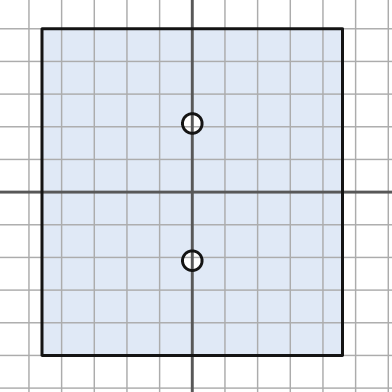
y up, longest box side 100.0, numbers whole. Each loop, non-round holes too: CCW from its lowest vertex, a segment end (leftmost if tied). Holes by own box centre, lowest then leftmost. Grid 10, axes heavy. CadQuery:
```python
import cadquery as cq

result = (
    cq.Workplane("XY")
    .moveTo(-46.0, -50.0)
    .lineTo(46.0, -50.0)
    .lineTo(46.0, 50.0)
    .lineTo(-46.0, 50.0)
    .close()
    .moveTo(0.0, -21.0)
    .circle(3.0)
    .moveTo(0.0, 21.0)
    .circle(3.0)
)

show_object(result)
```